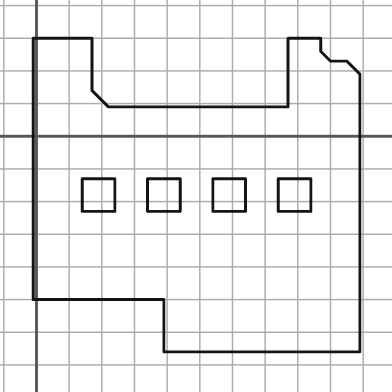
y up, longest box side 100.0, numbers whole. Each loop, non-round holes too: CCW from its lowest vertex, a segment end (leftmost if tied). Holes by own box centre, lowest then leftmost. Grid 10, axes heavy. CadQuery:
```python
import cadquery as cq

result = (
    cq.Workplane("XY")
    .moveTo(39.0, -66.0)
    .lineTo(99.0, -66.0)
    .lineTo(99.0, 19.0)
    .lineTo(95.0, 23.0)
    .lineTo(90.0, 23.0)
    .lineTo(87.0, 26.0)
    .lineTo(87.0, 30.0)
    .lineTo(77.0, 30.0)
    .lineTo(77.0, 9.0)
    .lineTo(22.0, 9.0)
    .lineTo(17.0, 14.0)
    .lineTo(17.0, 30.0)
    .lineTo(-1.0, 30.0)
    .lineTo(-1.0, -50.0)
    .lineTo(39.0, -50.0)
    .close()
    .moveTo(14.0, -23.0)
    .lineTo(24.0, -23.0)
    .lineTo(24.0, -13.0)
    .lineTo(14.0, -13.0)
    .close()
    .moveTo(34.0, -23.0)
    .lineTo(44.0, -23.0)
    .lineTo(44.0, -13.0)
    .lineTo(34.0, -13.0)
    .close()
    .moveTo(54.0, -23.0)
    .lineTo(64.0, -23.0)
    .lineTo(64.0, -13.0)
    .lineTo(54.0, -13.0)
    .close()
    .moveTo(74.0, -23.0)
    .lineTo(84.0, -23.0)
    .lineTo(84.0, -13.0)
    .lineTo(74.0, -13.0)
    .close()
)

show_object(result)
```